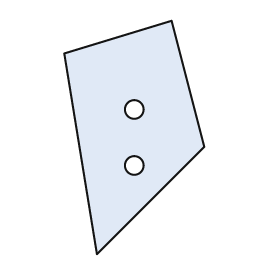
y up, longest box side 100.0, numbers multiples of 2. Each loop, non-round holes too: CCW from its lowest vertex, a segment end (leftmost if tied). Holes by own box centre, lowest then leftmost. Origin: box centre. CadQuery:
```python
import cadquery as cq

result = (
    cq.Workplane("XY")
    .moveTo(-16.0, -50.0)
    .lineTo(30.0, -4.0)
    .lineTo(16.0, 50.0)
    .lineTo(-30.0, 36.0)
    .close()
    .moveTo(0.0, -12.0)
    .circle(4.0)
    .moveTo(0.0, 12.0)
    .circle(4.0)
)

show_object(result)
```